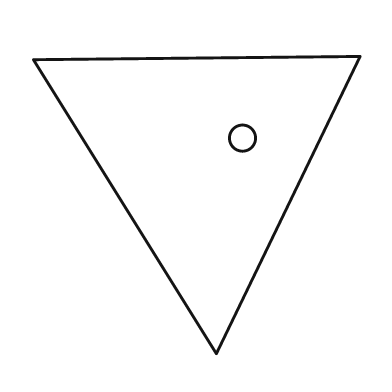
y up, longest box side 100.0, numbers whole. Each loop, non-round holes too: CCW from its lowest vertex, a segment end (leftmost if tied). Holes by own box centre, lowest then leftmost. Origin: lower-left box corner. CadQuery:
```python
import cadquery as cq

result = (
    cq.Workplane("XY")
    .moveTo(56.0, 0.0)
    .lineTo(100.0, 91.0)
    .lineTo(0.0, 90.0)
    .close()
    .moveTo(64.0, 66.0)
    .circle(4.0)
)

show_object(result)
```